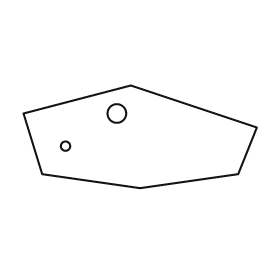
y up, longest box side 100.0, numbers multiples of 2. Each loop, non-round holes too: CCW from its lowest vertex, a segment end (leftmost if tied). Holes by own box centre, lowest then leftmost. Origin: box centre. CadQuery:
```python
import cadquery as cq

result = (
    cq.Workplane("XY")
    .moveTo(0.0, -22.0)
    .lineTo(42.0, -16.0)
    .lineTo(50.0, 4.0)
    .lineTo(-4.0, 22.0)
    .lineTo(-50.0, 10.0)
    .lineTo(-42.0, -16.0)
    .close()
    .moveTo(-32.0, -4.0)
    .circle(2.0)
    .moveTo(-10.0, 10.0)
    .circle(4.0)
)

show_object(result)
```